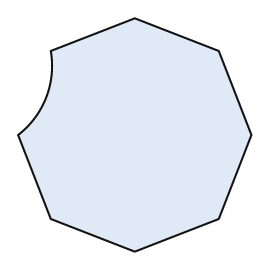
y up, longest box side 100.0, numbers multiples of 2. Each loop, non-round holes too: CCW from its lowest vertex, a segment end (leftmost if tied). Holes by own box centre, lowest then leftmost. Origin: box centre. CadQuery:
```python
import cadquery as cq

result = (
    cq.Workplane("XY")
    .moveTo(0.0, -50.0)
    .lineTo(36.0, -36.0)
    .lineTo(50.0, 0.0)
    .lineTo(36.0, 36.0)
    .lineTo(0.0, 50.0)
    .lineTo(-36.0, 36.0)
    .threePointArc((-38.0, 16.0), (-50.0, 0.0))
    .lineTo(-36.0, -36.0)
    .close()
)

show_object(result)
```